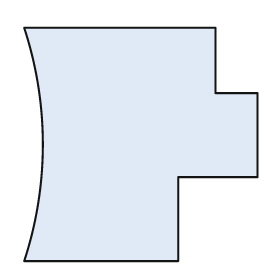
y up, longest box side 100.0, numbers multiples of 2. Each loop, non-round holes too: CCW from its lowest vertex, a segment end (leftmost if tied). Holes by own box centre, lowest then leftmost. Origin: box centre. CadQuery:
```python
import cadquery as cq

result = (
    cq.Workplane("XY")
    .moveTo(-50.0, -50.0)
    .lineTo(16.0, -50.0)
    .lineTo(16.0, -14.0)
    .lineTo(50.0, -14.0)
    .lineTo(50.0, 22.0)
    .lineTo(32.0, 22.0)
    .lineTo(32.0, 50.0)
    .lineTo(-50.0, 50.0)
    .threePointArc((-42.0, 0.0), (-50.0, -50.0))
    .close()
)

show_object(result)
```